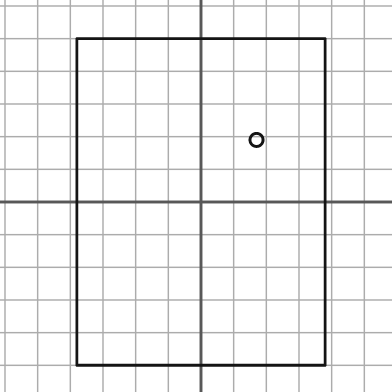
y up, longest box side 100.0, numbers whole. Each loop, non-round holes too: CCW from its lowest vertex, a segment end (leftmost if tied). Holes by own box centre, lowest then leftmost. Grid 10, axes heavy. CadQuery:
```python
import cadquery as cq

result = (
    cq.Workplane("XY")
    .moveTo(-38.0, -50.0)
    .lineTo(38.0, -50.0)
    .lineTo(38.0, 50.0)
    .lineTo(-38.0, 50.0)
    .close()
    .moveTo(17.0, 19.0)
    .circle(2.0)
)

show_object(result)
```